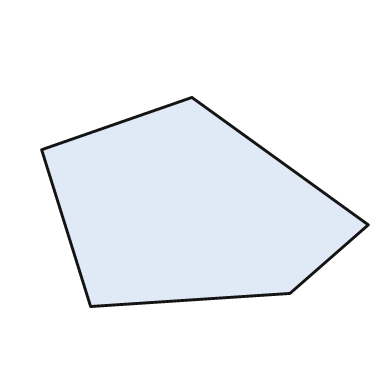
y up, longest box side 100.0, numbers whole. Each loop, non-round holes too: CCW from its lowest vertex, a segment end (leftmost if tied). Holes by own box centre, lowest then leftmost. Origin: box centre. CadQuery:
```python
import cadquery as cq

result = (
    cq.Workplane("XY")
    .moveTo(-35.0, -32.0)
    .lineTo(26.0, -28.0)
    .lineTo(50.0, -7.0)
    .lineTo(-4.0, 32.0)
    .lineTo(-50.0, 16.0)
    .close()
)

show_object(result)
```